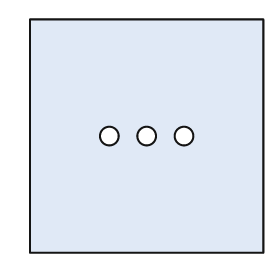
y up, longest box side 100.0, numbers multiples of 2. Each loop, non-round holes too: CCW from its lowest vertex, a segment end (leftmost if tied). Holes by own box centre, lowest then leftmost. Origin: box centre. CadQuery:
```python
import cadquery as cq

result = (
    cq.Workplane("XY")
    .moveTo(-50.0, -50.0)
    .lineTo(50.0, -50.0)
    .lineTo(50.0, 50.0)
    .lineTo(-50.0, 50.0)
    .close()
    .moveTo(-16.0, 0.0)
    .circle(4.0)
    .moveTo(0.0, 0.0)
    .circle(4.0)
    .moveTo(16.0, 0.0)
    .circle(4.0)
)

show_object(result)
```